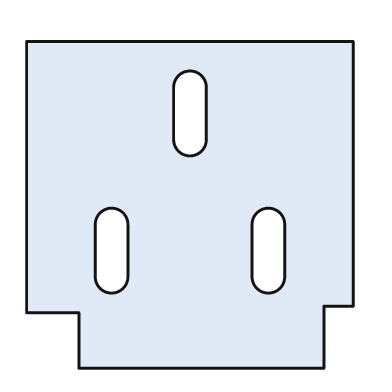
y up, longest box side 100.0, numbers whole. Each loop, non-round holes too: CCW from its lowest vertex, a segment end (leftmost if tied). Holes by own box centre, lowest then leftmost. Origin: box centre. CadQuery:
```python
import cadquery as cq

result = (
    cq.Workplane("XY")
    .moveTo(-34.0, -50.0)
    .lineTo(41.0, -50.0)
    .lineTo(41.0, -31.0)
    .lineTo(50.0, -31.0)
    .lineTo(50.0, 50.0)
    .lineTo(-50.0, 50.0)
    .lineTo(-50.0, -33.0)
    .lineTo(-34.0, -33.0)
    .close()
    .moveTo(-29.0, -22.0)
    .threePointArc((-24.0, -27.0), (-19.0, -22.0))
    .lineTo(-19.0, -6.0)
    .threePointArc((-24.0, -1.0), (-29.0, -6.0))
    .close()
    .moveTo(19.0, -22.0)
    .threePointArc((24.0, -27.0), (29.0, -22.0))
    .lineTo(29.0, -6.0)
    .threePointArc((24.0, -1.0), (19.0, -6.0))
    .close()
    .moveTo(-5.0, 20.0)
    .threePointArc((0.0, 15.0), (5.0, 20.0))
    .lineTo(5.0, 36.0)
    .threePointArc((0.0, 41.0), (-5.0, 36.0))
    .close()
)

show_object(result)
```